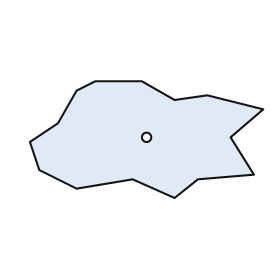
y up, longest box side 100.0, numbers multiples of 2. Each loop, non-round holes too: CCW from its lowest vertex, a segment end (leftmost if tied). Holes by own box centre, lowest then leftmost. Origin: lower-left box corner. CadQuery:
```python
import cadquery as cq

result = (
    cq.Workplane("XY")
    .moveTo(62.0, 0.0)
    .lineTo(72.0, 8.0)
    .lineTo(96.0, 10.0)
    .lineTo(86.0, 26.0)
    .lineTo(100.0, 38.0)
    .lineTo(76.0, 44.0)
    .lineTo(62.0, 42.0)
    .lineTo(48.0, 50.0)
    .lineTo(28.0, 50.0)
    .lineTo(20.0, 46.0)
    .lineTo(12.0, 32.0)
    .lineTo(0.0, 24.0)
    .lineTo(4.0, 12.0)
    .lineTo(20.0, 4.0)
    .lineTo(44.0, 8.0)
    .close()
    .moveTo(50.0, 26.0)
    .circle(2.0)
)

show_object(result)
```